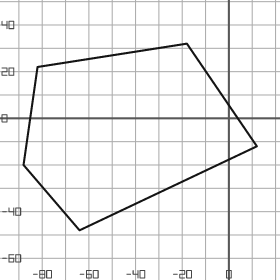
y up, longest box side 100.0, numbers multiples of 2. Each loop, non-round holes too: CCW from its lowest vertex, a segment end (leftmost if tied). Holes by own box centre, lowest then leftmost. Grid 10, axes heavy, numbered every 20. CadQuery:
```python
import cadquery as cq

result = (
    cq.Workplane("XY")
    .moveTo(-64.0, -48.0)
    .lineTo(12.0, -12.0)
    .lineTo(-18.0, 32.0)
    .lineTo(-82.0, 22.0)
    .lineTo(-88.0, -20.0)
    .close()
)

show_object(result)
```